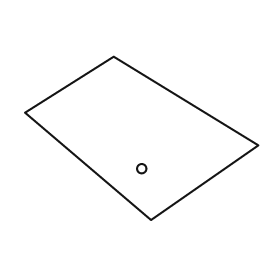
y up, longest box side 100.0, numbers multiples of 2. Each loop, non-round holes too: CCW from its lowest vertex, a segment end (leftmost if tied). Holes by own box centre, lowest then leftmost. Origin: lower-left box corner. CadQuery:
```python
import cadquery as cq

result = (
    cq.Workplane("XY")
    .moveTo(54.0, 0.0)
    .lineTo(100.0, 32.0)
    .lineTo(38.0, 70.0)
    .lineTo(0.0, 46.0)
    .close()
    .moveTo(50.0, 22.0)
    .circle(2.0)
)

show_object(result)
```